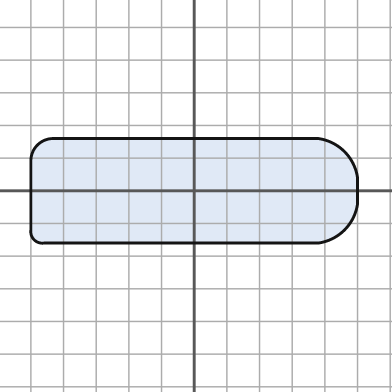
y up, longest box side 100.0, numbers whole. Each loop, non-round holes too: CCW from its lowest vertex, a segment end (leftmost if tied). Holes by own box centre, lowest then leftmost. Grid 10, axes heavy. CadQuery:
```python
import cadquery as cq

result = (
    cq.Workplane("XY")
    .moveTo(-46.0, -16.0)
    .lineTo(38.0, -16.0)
    .threePointArc((46.0, -12.0), (50.0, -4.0))
    .lineTo(50.0, 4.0)
    .threePointArc((46.0, 12.0), (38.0, 16.0))
    .lineTo(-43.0, 16.0)
    .threePointArc((-48.0, 14.0), (-50.0, 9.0))
    .lineTo(-50.0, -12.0)
    .threePointArc((-49.0, -15.0), (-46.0, -16.0))
    .close()
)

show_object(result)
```